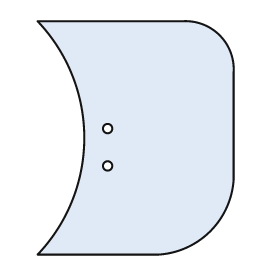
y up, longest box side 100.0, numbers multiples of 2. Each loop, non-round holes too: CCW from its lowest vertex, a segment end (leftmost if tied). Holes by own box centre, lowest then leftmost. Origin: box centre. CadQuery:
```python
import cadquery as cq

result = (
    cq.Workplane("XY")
    .moveTo(-42.0, -50.0)
    .lineTo(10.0, -50.0)
    .threePointArc((32.0, -40.0), (42.0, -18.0))
    .lineTo(42.0, 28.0)
    .threePointArc((36.0, 44.0), (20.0, 50.0))
    .lineTo(-42.0, 50.0)
    .threePointArc((-22.0, 0.0), (-42.0, -50.0))
    .close()
    .moveTo(-12.0, -12.0)
    .circle(2.0)
    .moveTo(-12.0, 4.0)
    .circle(2.0)
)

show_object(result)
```